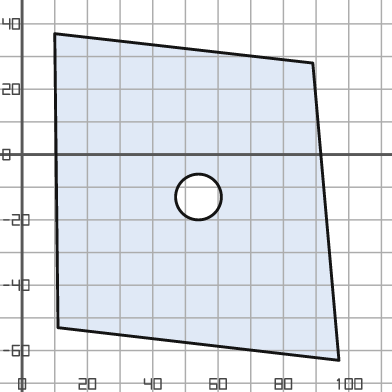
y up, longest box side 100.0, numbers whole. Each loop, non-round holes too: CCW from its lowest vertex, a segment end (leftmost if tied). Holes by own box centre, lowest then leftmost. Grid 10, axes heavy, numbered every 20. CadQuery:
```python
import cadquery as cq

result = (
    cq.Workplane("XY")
    .moveTo(97.0, -63.0)
    .lineTo(89.0, 28.0)
    .lineTo(10.0, 37.0)
    .lineTo(11.0, -53.0)
    .close()
    .moveTo(54.0, -13.0)
    .circle(7.0)
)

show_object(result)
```